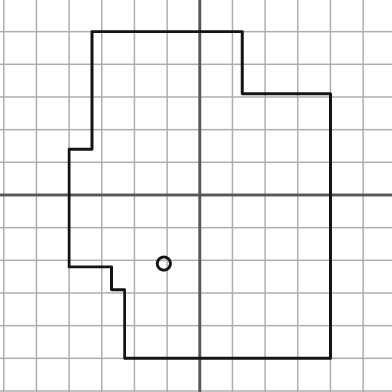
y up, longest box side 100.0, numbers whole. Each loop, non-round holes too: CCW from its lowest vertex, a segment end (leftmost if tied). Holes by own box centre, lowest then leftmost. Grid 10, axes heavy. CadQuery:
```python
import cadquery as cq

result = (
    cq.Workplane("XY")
    .moveTo(-23.0, -50.0)
    .lineTo(40.0, -50.0)
    .lineTo(40.0, 31.0)
    .lineTo(13.0, 31.0)
    .lineTo(13.0, 50.0)
    .lineTo(-33.0, 50.0)
    .lineTo(-33.0, 14.0)
    .lineTo(-40.0, 14.0)
    .lineTo(-40.0, -22.0)
    .lineTo(-27.0, -22.0)
    .lineTo(-27.0, -29.0)
    .lineTo(-23.0, -29.0)
    .close()
    .moveTo(-11.0, -21.0)
    .circle(2.0)
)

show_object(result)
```